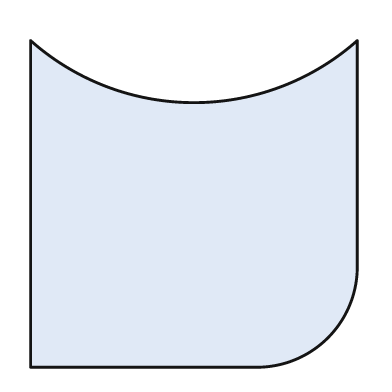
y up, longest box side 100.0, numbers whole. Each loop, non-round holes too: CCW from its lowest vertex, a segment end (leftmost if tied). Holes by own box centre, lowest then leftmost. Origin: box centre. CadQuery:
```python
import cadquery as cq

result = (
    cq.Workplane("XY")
    .moveTo(-50.0, -50.0)
    .lineTo(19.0, -50.0)
    .threePointArc((41.0, -41.0), (50.0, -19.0))
    .lineTo(50.0, 50.0)
    .threePointArc((0.0, 31.0), (-50.0, 50.0))
    .close()
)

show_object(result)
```